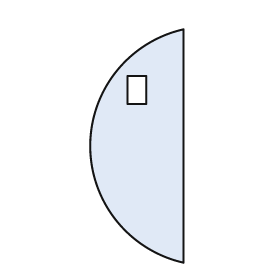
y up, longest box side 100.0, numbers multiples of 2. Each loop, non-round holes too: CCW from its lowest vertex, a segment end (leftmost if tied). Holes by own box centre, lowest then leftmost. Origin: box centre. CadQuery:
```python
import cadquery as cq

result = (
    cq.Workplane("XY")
    .moveTo(20.0, -50.0)
    .lineTo(20.0, 50.0)
    .threePointArc((-20.0, 0.0), (20.0, -50.0))
    .close()
    .moveTo(-4.0, 18.0)
    .lineTo(4.0, 18.0)
    .lineTo(4.0, 30.0)
    .lineTo(-4.0, 30.0)
    .close()
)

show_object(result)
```